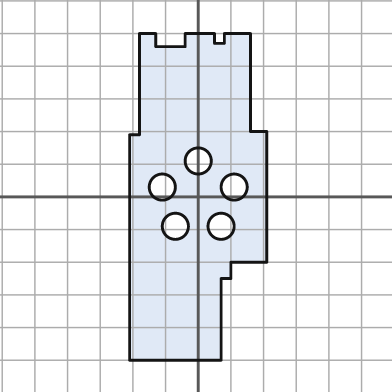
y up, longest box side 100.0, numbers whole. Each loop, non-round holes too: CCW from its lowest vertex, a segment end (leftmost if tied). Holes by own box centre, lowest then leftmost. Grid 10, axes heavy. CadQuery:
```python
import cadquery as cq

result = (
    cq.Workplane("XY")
    .moveTo(-21.0, -50.0)
    .lineTo(7.0, -50.0)
    .lineTo(7.0, -25.0)
    .lineTo(10.0, -25.0)
    .lineTo(10.0, -20.0)
    .lineTo(21.0, -20.0)
    .lineTo(21.0, 20.0)
    .lineTo(16.0, 20.0)
    .lineTo(16.0, 50.0)
    .lineTo(8.0, 50.0)
    .lineTo(8.0, 47.0)
    .lineTo(5.0, 47.0)
    .lineTo(5.0, 50.0)
    .lineTo(-4.0, 50.0)
    .lineTo(-4.0, 46.0)
    .lineTo(-13.0, 46.0)
    .lineTo(-13.0, 50.0)
    .lineTo(-18.0, 50.0)
    .lineTo(-18.0, 19.0)
    .lineTo(-21.0, 19.0)
    .close()
    .moveTo(-7.0, -9.0)
    .circle(4.0)
    .moveTo(7.0, -9.0)
    .circle(4.0)
    .moveTo(-11.0, 3.0)
    .circle(4.0)
    .moveTo(11.0, 3.0)
    .circle(4.0)
    .moveTo(0.0, 11.0)
    .circle(4.0)
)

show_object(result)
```